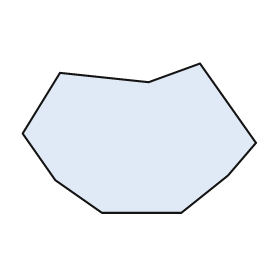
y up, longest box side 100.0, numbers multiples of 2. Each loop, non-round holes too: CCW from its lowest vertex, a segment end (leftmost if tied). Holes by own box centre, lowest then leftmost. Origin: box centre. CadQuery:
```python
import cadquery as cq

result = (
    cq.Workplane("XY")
    .moveTo(-16.0, -32.0)
    .lineTo(18.0, -32.0)
    .lineTo(38.0, -16.0)
    .lineTo(50.0, -2.0)
    .lineTo(26.0, 32.0)
    .lineTo(4.0, 24.0)
    .lineTo(-34.0, 28.0)
    .lineTo(-50.0, 2.0)
    .lineTo(-36.0, -18.0)
    .close()
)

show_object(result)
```